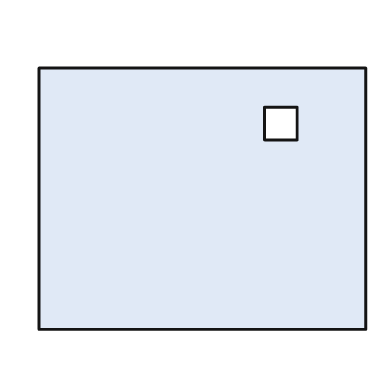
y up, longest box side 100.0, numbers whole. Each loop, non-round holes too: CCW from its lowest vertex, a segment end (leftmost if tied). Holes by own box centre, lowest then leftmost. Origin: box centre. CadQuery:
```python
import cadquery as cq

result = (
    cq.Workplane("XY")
    .moveTo(-50.0, -40.0)
    .lineTo(50.0, -40.0)
    .lineTo(50.0, 40.0)
    .lineTo(-50.0, 40.0)
    .close()
    .moveTo(19.0, 18.0)
    .lineTo(29.0, 18.0)
    .lineTo(29.0, 28.0)
    .lineTo(19.0, 28.0)
    .close()
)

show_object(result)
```